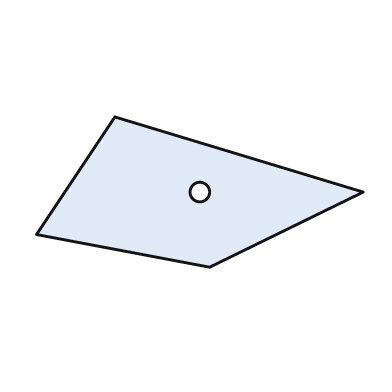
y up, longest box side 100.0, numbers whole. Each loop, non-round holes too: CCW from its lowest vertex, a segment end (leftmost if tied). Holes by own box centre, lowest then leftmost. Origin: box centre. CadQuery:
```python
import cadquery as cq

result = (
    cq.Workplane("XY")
    .moveTo(3.0, -23.0)
    .lineTo(50.0, 0.0)
    .lineTo(-26.0, 23.0)
    .lineTo(-50.0, -13.0)
    .close()
    .moveTo(0.0, 0.0)
    .circle(3.0)
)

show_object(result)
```